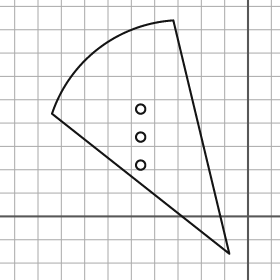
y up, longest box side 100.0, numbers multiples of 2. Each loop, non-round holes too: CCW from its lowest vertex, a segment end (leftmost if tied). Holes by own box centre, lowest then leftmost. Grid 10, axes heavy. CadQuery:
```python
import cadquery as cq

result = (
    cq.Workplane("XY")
    .moveTo(-8.0, -16.0)
    .lineTo(-32.0, 84.0)
    .threePointArc((-64.0, 72.0), (-84.0, 44.0))
    .close()
    .moveTo(-46.0, 22.0)
    .circle(2.0)
    .moveTo(-46.0, 34.0)
    .circle(2.0)
    .moveTo(-46.0, 46.0)
    .circle(2.0)
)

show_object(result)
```